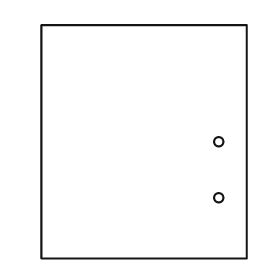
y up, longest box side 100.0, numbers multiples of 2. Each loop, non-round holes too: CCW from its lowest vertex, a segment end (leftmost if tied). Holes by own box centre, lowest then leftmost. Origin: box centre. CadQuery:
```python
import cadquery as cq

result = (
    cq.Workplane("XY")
    .moveTo(-44.0, -50.0)
    .lineTo(44.0, -50.0)
    .lineTo(44.0, 50.0)
    .lineTo(-44.0, 50.0)
    .close()
    .moveTo(32.0, -24.0)
    .circle(2.0)
    .moveTo(32.0, 0.0)
    .circle(2.0)
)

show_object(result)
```